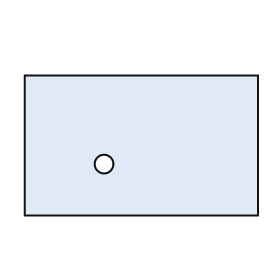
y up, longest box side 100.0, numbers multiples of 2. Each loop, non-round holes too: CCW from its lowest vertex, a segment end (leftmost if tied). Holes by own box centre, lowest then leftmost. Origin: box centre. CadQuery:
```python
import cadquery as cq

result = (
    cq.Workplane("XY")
    .moveTo(-50.0, -30.0)
    .lineTo(50.0, -30.0)
    .lineTo(50.0, 30.0)
    .lineTo(-50.0, 30.0)
    .close()
    .moveTo(-16.0, -8.0)
    .circle(4.0)
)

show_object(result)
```